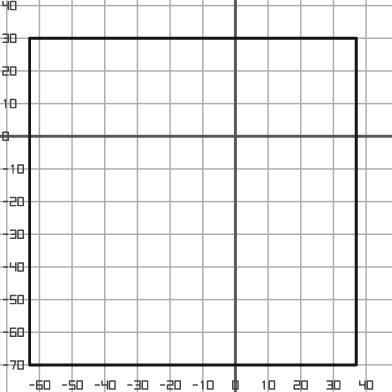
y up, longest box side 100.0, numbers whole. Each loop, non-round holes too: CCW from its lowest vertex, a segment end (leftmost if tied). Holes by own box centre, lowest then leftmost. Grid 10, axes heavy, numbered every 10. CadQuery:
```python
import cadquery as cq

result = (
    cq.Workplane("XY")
    .moveTo(-63.0, -70.0)
    .lineTo(37.0, -70.0)
    .lineTo(37.0, 30.0)
    .lineTo(-63.0, 30.0)
    .close()
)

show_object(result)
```